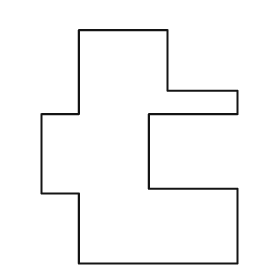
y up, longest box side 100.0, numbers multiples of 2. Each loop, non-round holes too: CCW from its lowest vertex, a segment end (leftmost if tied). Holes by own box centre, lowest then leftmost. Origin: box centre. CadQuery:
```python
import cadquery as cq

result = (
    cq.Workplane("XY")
    .moveTo(-26.0, -50.0)
    .lineTo(42.0, -50.0)
    .lineTo(42.0, -18.0)
    .lineTo(4.0, -18.0)
    .lineTo(4.0, 14.0)
    .lineTo(42.0, 14.0)
    .lineTo(42.0, 24.0)
    .lineTo(12.0, 24.0)
    .lineTo(12.0, 50.0)
    .lineTo(-26.0, 50.0)
    .lineTo(-26.0, 14.0)
    .lineTo(-42.0, 14.0)
    .lineTo(-42.0, -20.0)
    .lineTo(-26.0, -20.0)
    .close()
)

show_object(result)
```